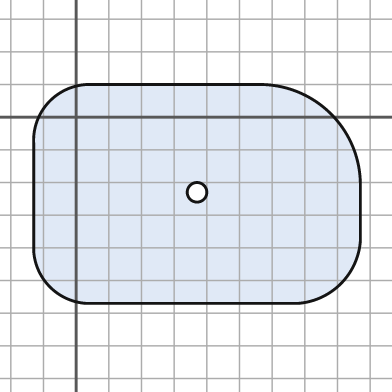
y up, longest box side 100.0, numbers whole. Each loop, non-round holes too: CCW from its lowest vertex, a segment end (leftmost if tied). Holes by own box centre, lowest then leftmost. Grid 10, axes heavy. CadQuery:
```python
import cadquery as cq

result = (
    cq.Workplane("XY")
    .moveTo(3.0, -57.0)
    .lineTo(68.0, -57.0)
    .threePointArc((81.0, -51.0), (87.0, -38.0))
    .lineTo(87.0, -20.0)
    .threePointArc((78.0, 1.0), (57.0, 10.0))
    .lineTo(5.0, 10.0)
    .threePointArc((-8.0, 5.0), (-13.0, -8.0))
    .lineTo(-13.0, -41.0)
    .threePointArc((-8.0, -52.0), (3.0, -57.0))
    .close()
    .moveTo(37.0, -23.0)
    .circle(3.0)
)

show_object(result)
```